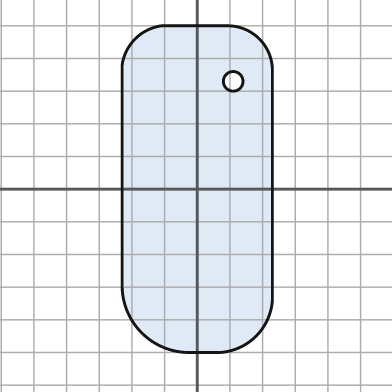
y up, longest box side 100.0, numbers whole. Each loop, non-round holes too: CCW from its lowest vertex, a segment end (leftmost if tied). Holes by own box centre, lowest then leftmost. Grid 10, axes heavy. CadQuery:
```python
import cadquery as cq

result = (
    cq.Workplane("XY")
    .moveTo(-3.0, -50.0)
    .lineTo(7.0, -50.0)
    .threePointArc((18.0, -45.0), (23.0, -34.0))
    .lineTo(23.0, 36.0)
    .threePointArc((19.0, 46.0), (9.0, 50.0))
    .lineTo(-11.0, 50.0)
    .threePointArc((-19.0, 46.0), (-23.0, 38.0))
    .lineTo(-23.0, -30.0)
    .threePointArc((-17.0, -44.0), (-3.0, -50.0))
    .close()
    .moveTo(11.0, 33.0)
    .circle(3.0)
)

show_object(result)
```